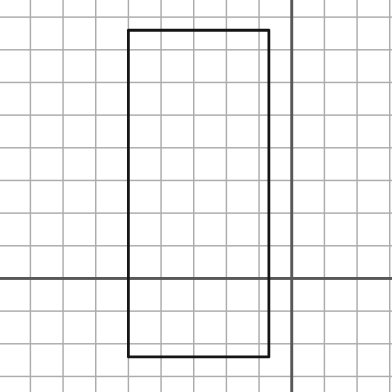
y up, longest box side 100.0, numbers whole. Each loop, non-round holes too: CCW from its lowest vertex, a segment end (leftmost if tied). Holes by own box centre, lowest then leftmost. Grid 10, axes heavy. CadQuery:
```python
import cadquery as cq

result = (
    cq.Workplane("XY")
    .moveTo(-50.0, -24.0)
    .lineTo(-7.0, -24.0)
    .lineTo(-7.0, 76.0)
    .lineTo(-50.0, 76.0)
    .close()
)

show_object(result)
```